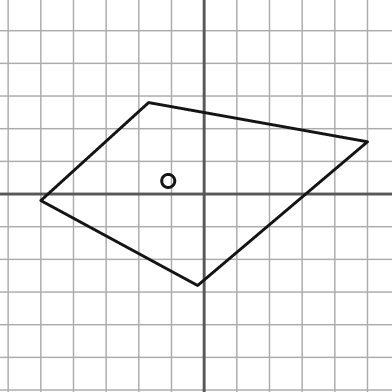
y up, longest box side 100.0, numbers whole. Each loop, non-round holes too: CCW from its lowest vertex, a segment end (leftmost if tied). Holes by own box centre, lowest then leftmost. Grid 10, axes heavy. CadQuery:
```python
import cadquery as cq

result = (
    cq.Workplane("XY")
    .moveTo(-2.0, -28.0)
    .lineTo(50.0, 16.0)
    .lineTo(-17.0, 28.0)
    .lineTo(-50.0, -2.0)
    .close()
    .moveTo(-11.0, 4.0)
    .circle(2.0)
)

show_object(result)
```